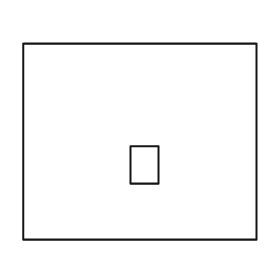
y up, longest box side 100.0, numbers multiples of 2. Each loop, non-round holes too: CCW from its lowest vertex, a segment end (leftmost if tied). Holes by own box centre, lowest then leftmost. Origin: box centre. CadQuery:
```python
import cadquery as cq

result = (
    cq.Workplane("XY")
    .moveTo(-50.0, -42.0)
    .lineTo(50.0, -42.0)
    .lineTo(50.0, 42.0)
    .lineTo(-50.0, 42.0)
    .close()
    .moveTo(-4.0, -18.0)
    .lineTo(8.0, -18.0)
    .lineTo(8.0, -2.0)
    .lineTo(-4.0, -2.0)
    .close()
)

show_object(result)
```